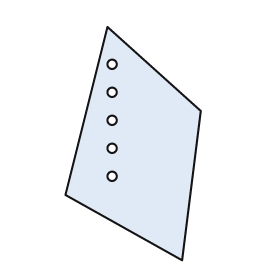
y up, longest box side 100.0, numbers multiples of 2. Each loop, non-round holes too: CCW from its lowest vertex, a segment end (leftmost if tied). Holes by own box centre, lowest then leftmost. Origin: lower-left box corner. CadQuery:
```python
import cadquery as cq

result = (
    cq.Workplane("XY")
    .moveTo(50.0, 0.0)
    .lineTo(58.0, 64.0)
    .lineTo(18.0, 100.0)
    .lineTo(0.0, 28.0)
    .close()
    .moveTo(20.0, 36.0)
    .circle(2.0)
    .moveTo(20.0, 48.0)
    .circle(2.0)
    .moveTo(20.0, 60.0)
    .circle(2.0)
    .moveTo(20.0, 72.0)
    .circle(2.0)
    .moveTo(20.0, 84.0)
    .circle(2.0)
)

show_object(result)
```